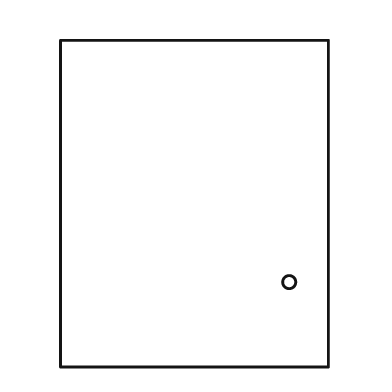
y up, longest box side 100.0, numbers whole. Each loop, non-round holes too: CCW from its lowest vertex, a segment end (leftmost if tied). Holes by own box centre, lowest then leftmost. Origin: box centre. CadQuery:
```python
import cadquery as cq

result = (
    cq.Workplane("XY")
    .moveTo(-41.0, -50.0)
    .lineTo(41.0, -50.0)
    .lineTo(41.0, 50.0)
    .lineTo(-41.0, 50.0)
    .close()
    .moveTo(29.0, -24.0)
    .circle(2.0)
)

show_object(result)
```